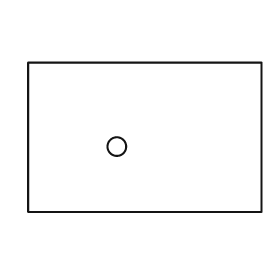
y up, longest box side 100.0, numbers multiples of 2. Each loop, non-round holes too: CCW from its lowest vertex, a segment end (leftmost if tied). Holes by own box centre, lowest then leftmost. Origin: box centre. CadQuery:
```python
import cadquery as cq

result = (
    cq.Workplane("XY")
    .moveTo(-50.0, -32.0)
    .lineTo(50.0, -32.0)
    .lineTo(50.0, 32.0)
    .lineTo(-50.0, 32.0)
    .close()
    .moveTo(-12.0, -4.0)
    .circle(4.0)
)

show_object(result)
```